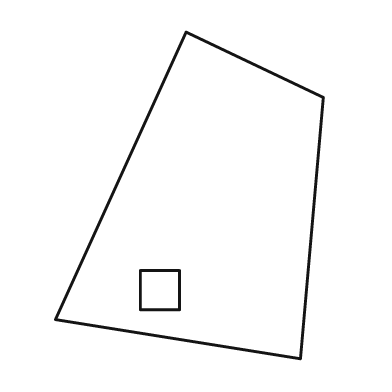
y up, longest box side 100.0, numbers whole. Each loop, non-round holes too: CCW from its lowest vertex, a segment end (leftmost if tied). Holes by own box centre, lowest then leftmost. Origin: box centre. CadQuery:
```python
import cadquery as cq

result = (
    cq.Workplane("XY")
    .moveTo(34.0, -50.0)
    .lineTo(41.0, 30.0)
    .lineTo(-1.0, 50.0)
    .lineTo(-41.0, -38.0)
    .close()
    .moveTo(-15.0, -35.0)
    .lineTo(-3.0, -35.0)
    .lineTo(-3.0, -23.0)
    .lineTo(-15.0, -23.0)
    .close()
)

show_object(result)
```